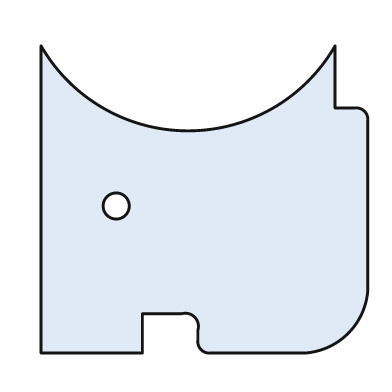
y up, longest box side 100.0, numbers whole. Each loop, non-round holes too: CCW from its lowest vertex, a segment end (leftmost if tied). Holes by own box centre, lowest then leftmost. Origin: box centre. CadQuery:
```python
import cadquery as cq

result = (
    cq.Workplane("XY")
    .moveTo(-50.0, -47.0)
    .lineTo(-19.0, -47.0)
    .lineTo(-19.0, -35.0)
    .lineTo(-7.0, -35.0)
    .threePointArc((-3.0, -36.0), (-2.0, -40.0))
    .lineTo(-2.0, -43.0)
    .threePointArc((-1.0, -46.0), (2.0, -47.0))
    .lineTo(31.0, -47.0)
    .threePointArc((44.0, -41.0), (50.0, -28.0))
    .lineTo(50.0, 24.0)
    .threePointArc((49.0, 27.0), (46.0, 28.0))
    .lineTo(40.0, 28.0)
    .lineTo(40.0, 47.0)
    .threePointArc((-5.0, 21.0), (-50.0, 47.0))
    .close()
    .moveTo(-27.0, -2.0)
    .circle(4.0)
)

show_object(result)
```